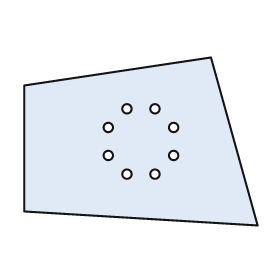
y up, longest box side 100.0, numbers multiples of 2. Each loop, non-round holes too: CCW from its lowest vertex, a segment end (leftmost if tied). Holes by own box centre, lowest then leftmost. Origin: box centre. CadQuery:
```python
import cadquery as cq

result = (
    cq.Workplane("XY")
    .moveTo(50.0, -36.0)
    .lineTo(30.0, 36.0)
    .lineTo(-50.0, 24.0)
    .lineTo(-50.0, -30.0)
    .close()
    .moveTo(-6.0, -14.0)
    .circle(2.0)
    .moveTo(6.0, -14.0)
    .circle(2.0)
    .moveTo(-14.0, -6.0)
    .circle(2.0)
    .moveTo(14.0, -6.0)
    .circle(2.0)
    .moveTo(-14.0, 6.0)
    .circle(2.0)
    .moveTo(14.0, 6.0)
    .circle(2.0)
    .moveTo(-6.0, 14.0)
    .circle(2.0)
    .moveTo(6.0, 14.0)
    .circle(2.0)
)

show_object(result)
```